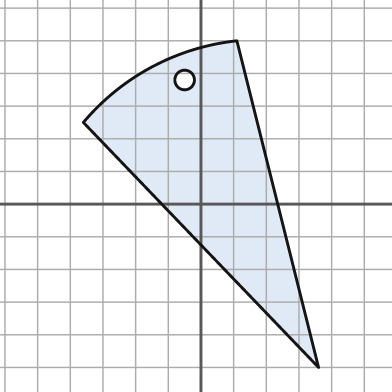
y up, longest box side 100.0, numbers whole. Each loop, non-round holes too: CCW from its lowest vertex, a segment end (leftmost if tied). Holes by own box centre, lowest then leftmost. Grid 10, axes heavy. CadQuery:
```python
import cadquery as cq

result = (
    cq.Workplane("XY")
    .moveTo(36.0, -50.0)
    .lineTo(11.0, 50.0)
    .threePointArc((-15.0, 42.0), (-36.0, 25.0))
    .close()
    .moveTo(-5.0, 38.0)
    .circle(3.0)
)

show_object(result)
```